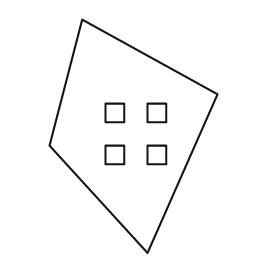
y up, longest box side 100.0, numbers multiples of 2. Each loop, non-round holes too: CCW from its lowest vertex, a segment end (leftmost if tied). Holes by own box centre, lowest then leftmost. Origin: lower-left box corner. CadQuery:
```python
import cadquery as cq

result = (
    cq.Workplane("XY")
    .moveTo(42.0, 0.0)
    .lineTo(72.0, 68.0)
    .lineTo(14.0, 100.0)
    .lineTo(0.0, 46.0)
    .close()
    .moveTo(24.0, 38.0)
    .lineTo(32.0, 38.0)
    .lineTo(32.0, 46.0)
    .lineTo(24.0, 46.0)
    .close()
    .moveTo(42.0, 38.0)
    .lineTo(50.0, 38.0)
    .lineTo(50.0, 46.0)
    .lineTo(42.0, 46.0)
    .close()
    .moveTo(24.0, 56.0)
    .lineTo(32.0, 56.0)
    .lineTo(32.0, 64.0)
    .lineTo(24.0, 64.0)
    .close()
    .moveTo(42.0, 56.0)
    .lineTo(50.0, 56.0)
    .lineTo(50.0, 64.0)
    .lineTo(42.0, 64.0)
    .close()
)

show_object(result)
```